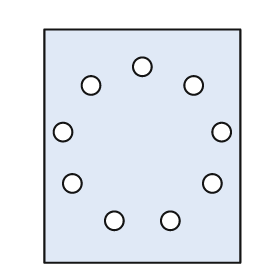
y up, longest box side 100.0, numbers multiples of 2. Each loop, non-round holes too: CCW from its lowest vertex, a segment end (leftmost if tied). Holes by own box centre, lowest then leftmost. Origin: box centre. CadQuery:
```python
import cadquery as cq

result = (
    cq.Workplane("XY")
    .moveTo(-42.0, -50.0)
    .lineTo(42.0, -50.0)
    .lineTo(42.0, 50.0)
    .lineTo(-42.0, 50.0)
    .close()
    .moveTo(-12.0, -32.0)
    .circle(4.0)
    .moveTo(12.0, -32.0)
    .circle(4.0)
    .moveTo(-30.0, -16.0)
    .circle(4.0)
    .moveTo(30.0, -16.0)
    .circle(4.0)
    .moveTo(-34.0, 6.0)
    .circle(4.0)
    .moveTo(34.0, 6.0)
    .circle(4.0)
    .moveTo(-22.0, 26.0)
    .circle(4.0)
    .moveTo(22.0, 26.0)
    .circle(4.0)
    .moveTo(0.0, 34.0)
    .circle(4.0)
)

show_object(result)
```